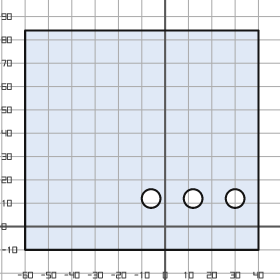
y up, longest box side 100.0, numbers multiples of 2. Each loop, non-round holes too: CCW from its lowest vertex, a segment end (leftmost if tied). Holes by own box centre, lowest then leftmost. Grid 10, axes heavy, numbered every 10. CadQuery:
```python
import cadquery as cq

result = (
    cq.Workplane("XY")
    .moveTo(-60.0, -10.0)
    .lineTo(40.0, -10.0)
    .lineTo(40.0, 84.0)
    .lineTo(-60.0, 84.0)
    .close()
    .moveTo(-6.0, 12.0)
    .circle(4.0)
    .moveTo(12.0, 12.0)
    .circle(4.0)
    .moveTo(30.0, 12.0)
    .circle(4.0)
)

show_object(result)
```